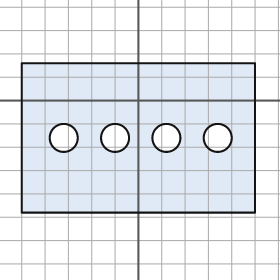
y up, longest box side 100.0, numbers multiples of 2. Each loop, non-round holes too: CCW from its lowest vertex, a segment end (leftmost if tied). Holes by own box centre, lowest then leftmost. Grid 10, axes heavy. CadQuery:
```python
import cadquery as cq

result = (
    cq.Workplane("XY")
    .moveTo(-50.0, -48.0)
    .lineTo(50.0, -48.0)
    .lineTo(50.0, 16.0)
    .lineTo(-50.0, 16.0)
    .close()
    .moveTo(-32.0, -16.0)
    .circle(6.0)
    .moveTo(-10.0, -16.0)
    .circle(6.0)
    .moveTo(12.0, -16.0)
    .circle(6.0)
    .moveTo(34.0, -16.0)
    .circle(6.0)
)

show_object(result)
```